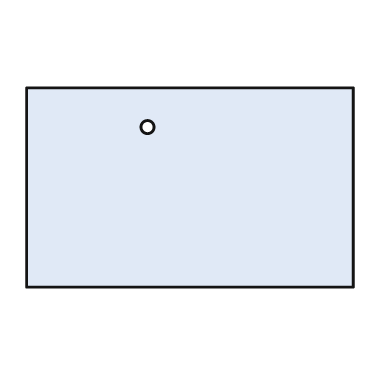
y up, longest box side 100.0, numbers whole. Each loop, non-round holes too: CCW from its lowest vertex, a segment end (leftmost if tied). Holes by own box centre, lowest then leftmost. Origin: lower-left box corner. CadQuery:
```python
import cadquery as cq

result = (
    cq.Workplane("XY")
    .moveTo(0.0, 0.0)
    .lineTo(100.0, 0.0)
    .lineTo(100.0, 61.0)
    .lineTo(0.0, 61.0)
    .close()
    .moveTo(37.0, 49.0)
    .circle(2.0)
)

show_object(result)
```